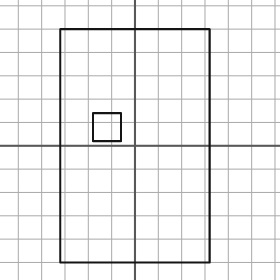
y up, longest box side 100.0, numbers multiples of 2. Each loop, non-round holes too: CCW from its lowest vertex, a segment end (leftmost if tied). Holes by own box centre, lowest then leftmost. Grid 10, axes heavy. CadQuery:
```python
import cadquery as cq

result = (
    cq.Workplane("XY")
    .moveTo(-32.0, -50.0)
    .lineTo(32.0, -50.0)
    .lineTo(32.0, 50.0)
    .lineTo(-32.0, 50.0)
    .close()
    .moveTo(-18.0, 2.0)
    .lineTo(-6.0, 2.0)
    .lineTo(-6.0, 14.0)
    .lineTo(-18.0, 14.0)
    .close()
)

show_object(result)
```